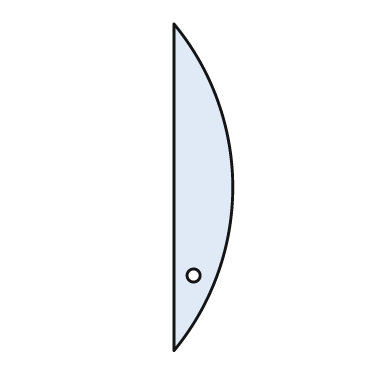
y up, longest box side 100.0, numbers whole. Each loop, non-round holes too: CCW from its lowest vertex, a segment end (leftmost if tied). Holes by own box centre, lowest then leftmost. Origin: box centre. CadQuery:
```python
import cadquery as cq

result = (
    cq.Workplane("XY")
    .moveTo(-9.0, -50.0)
    .threePointArc((9.0, 0.0), (-9.0, 50.0))
    .close()
    .moveTo(-3.0, -27.0)
    .circle(2.0)
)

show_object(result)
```